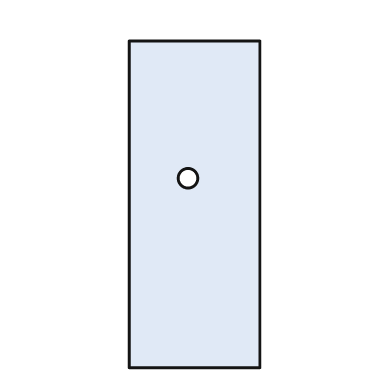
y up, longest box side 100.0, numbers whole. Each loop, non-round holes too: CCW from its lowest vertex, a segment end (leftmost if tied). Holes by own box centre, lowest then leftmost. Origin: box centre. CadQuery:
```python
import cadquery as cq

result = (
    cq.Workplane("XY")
    .moveTo(-20.0, -50.0)
    .lineTo(20.0, -50.0)
    .lineTo(20.0, 50.0)
    .lineTo(-20.0, 50.0)
    .close()
    .moveTo(-2.0, 8.0)
    .circle(3.0)
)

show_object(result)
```